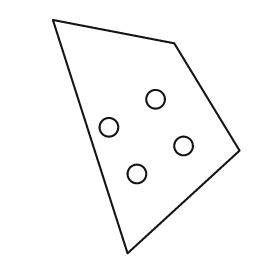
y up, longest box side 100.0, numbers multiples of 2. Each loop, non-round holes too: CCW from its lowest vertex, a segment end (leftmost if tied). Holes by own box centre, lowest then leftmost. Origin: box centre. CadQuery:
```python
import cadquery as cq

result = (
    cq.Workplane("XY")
    .moveTo(-8.0, -50.0)
    .lineTo(40.0, -6.0)
    .lineTo(12.0, 40.0)
    .lineTo(-40.0, 50.0)
    .close()
    .moveTo(-4.0, -16.0)
    .circle(4.0)
    .moveTo(16.0, -4.0)
    .circle(4.0)
    .moveTo(-16.0, 4.0)
    .circle(4.0)
    .moveTo(4.0, 16.0)
    .circle(4.0)
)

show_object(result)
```